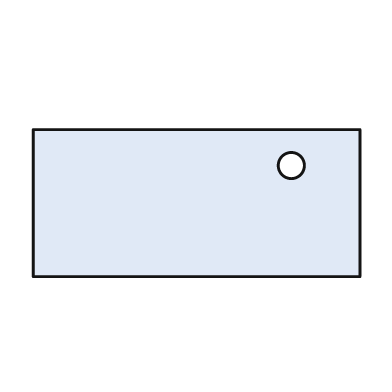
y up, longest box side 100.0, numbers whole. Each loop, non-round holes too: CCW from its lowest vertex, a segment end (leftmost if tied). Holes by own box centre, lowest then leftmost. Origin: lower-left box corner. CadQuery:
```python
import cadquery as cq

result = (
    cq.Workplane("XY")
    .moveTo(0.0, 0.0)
    .lineTo(100.0, 0.0)
    .lineTo(100.0, 45.0)
    .lineTo(0.0, 45.0)
    .close()
    .moveTo(79.0, 34.0)
    .circle(4.0)
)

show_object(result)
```